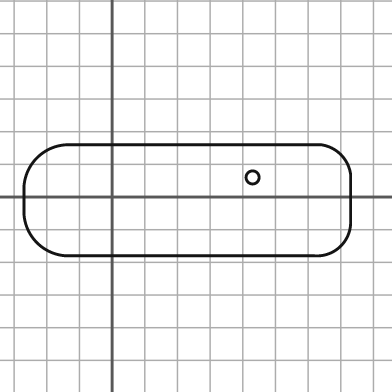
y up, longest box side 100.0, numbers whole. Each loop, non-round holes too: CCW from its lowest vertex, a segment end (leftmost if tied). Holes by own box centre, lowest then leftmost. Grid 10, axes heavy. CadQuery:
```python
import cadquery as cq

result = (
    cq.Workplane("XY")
    .moveTo(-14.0, -18.0)
    .lineTo(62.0, -18.0)
    .threePointArc((70.0, -15.0), (73.0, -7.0))
    .lineTo(73.0, 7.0)
    .threePointArc((70.0, 13.0), (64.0, 16.0))
    .lineTo(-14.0, 16.0)
    .threePointArc((-23.0, 12.0), (-27.0, 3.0))
    .lineTo(-27.0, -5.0)
    .threePointArc((-23.0, -14.0), (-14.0, -18.0))
    .close()
    .moveTo(43.0, 6.0)
    .circle(2.0)
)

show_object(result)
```